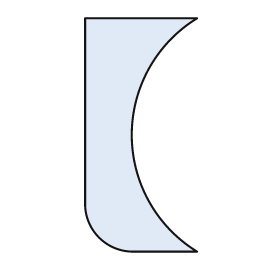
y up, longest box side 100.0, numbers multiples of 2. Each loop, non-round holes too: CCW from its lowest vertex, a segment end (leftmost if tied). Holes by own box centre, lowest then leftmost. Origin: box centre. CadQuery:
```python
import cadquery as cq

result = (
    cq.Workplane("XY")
    .moveTo(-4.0, -50.0)
    .lineTo(24.0, -50.0)
    .threePointArc((-4.0, 0.0), (24.0, 50.0))
    .lineTo(-24.0, 50.0)
    .lineTo(-24.0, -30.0)
    .threePointArc((-18.0, -44.0), (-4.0, -50.0))
    .close()
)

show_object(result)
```